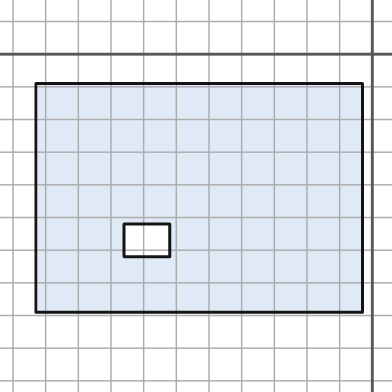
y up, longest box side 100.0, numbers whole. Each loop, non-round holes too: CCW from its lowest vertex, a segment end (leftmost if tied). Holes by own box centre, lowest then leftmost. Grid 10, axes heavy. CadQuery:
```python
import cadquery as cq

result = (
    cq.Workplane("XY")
    .moveTo(-103.0, -79.0)
    .lineTo(-3.0, -79.0)
    .lineTo(-3.0, -9.0)
    .lineTo(-103.0, -9.0)
    .close()
    .moveTo(-76.0, -62.0)
    .lineTo(-62.0, -62.0)
    .lineTo(-62.0, -52.0)
    .lineTo(-76.0, -52.0)
    .close()
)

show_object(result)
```